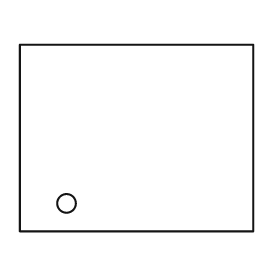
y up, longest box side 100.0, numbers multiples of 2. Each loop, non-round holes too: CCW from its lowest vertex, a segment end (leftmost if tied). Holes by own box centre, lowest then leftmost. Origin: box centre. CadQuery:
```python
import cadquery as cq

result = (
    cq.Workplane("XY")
    .moveTo(-50.0, -40.0)
    .lineTo(50.0, -40.0)
    .lineTo(50.0, 40.0)
    .lineTo(-50.0, 40.0)
    .close()
    .moveTo(-30.0, -28.0)
    .circle(4.0)
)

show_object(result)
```